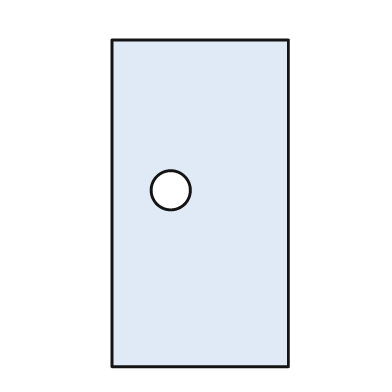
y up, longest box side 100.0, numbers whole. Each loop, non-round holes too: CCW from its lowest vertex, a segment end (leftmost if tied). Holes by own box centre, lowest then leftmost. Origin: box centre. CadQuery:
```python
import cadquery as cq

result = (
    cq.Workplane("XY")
    .moveTo(-27.0, -50.0)
    .lineTo(27.0, -50.0)
    .lineTo(27.0, 50.0)
    .lineTo(-27.0, 50.0)
    .close()
    .moveTo(-9.0, 4.0)
    .circle(6.0)
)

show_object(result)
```